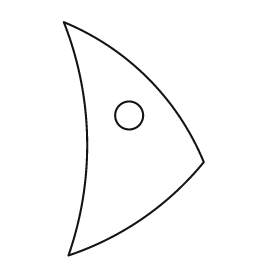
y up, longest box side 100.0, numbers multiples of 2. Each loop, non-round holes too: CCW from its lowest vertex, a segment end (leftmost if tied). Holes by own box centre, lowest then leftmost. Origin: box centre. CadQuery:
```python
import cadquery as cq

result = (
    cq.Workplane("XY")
    .moveTo(-28.0, -50.0)
    .threePointArc((4.0, -34.0), (30.0, -10.0))
    .threePointArc((6.0, 26.0), (-30.0, 50.0))
    .threePointArc((-20.0, 0.0), (-28.0, -50.0))
    .close()
    .moveTo(-2.0, 10.0)
    .circle(6.0)
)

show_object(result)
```